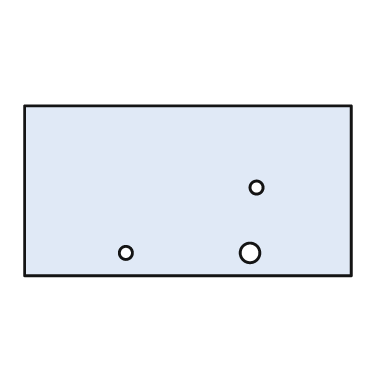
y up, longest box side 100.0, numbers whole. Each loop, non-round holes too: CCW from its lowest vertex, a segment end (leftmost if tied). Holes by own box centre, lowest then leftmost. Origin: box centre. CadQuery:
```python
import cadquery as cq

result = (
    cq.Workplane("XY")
    .moveTo(-50.0, -26.0)
    .lineTo(50.0, -26.0)
    .lineTo(50.0, 26.0)
    .lineTo(-50.0, 26.0)
    .close()
    .moveTo(-19.0, -19.0)
    .circle(2.0)
    .moveTo(19.0, -19.0)
    .circle(3.0)
    .moveTo(21.0, 1.0)
    .circle(2.0)
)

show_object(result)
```